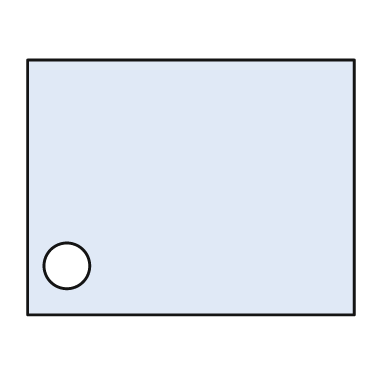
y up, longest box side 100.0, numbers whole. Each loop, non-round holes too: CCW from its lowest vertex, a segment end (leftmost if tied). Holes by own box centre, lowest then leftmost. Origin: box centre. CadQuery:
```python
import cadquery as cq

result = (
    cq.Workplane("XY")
    .moveTo(-50.0, -39.0)
    .lineTo(50.0, -39.0)
    .lineTo(50.0, 39.0)
    .lineTo(-50.0, 39.0)
    .close()
    .moveTo(-38.0, -24.0)
    .circle(7.0)
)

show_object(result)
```